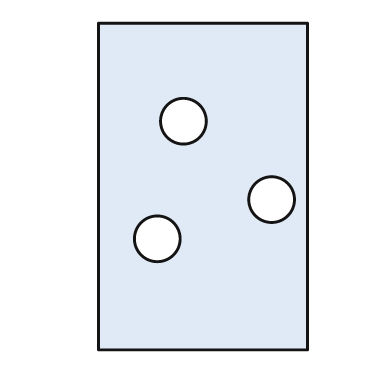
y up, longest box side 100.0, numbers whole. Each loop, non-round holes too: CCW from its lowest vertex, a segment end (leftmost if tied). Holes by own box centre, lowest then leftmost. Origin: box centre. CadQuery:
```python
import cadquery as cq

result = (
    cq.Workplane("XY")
    .moveTo(-32.0, -50.0)
    .lineTo(32.0, -50.0)
    .lineTo(32.0, 50.0)
    .lineTo(-32.0, 50.0)
    .close()
    .moveTo(-14.0, -16.0)
    .circle(7.0)
    .moveTo(21.0, -4.0)
    .circle(7.0)
    .moveTo(-6.0, 20.0)
    .circle(7.0)
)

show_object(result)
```